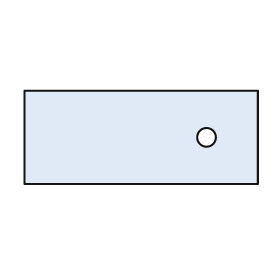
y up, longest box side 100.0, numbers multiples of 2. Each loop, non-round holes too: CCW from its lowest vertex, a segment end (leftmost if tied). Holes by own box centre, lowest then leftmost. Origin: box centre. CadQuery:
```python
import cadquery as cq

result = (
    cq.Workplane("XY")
    .moveTo(-50.0, -20.0)
    .lineTo(50.0, -20.0)
    .lineTo(50.0, 20.0)
    .lineTo(-50.0, 20.0)
    .close()
    .moveTo(28.0, 0.0)
    .circle(4.0)
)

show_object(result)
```